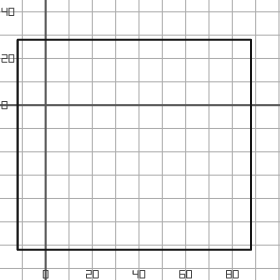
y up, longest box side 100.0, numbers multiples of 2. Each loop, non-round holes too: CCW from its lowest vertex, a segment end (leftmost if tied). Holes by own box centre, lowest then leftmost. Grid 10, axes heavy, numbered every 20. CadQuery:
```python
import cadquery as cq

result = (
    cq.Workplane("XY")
    .moveTo(-12.0, -62.0)
    .lineTo(88.0, -62.0)
    .lineTo(88.0, 28.0)
    .lineTo(-12.0, 28.0)
    .close()
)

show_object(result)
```